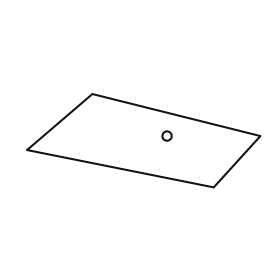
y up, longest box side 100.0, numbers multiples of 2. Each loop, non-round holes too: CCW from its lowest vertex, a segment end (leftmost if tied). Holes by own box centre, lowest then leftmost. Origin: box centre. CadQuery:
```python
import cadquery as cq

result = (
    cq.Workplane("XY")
    .moveTo(30.0, -20.0)
    .lineTo(50.0, 2.0)
    .lineTo(-22.0, 20.0)
    .lineTo(-50.0, -4.0)
    .close()
    .moveTo(10.0, 2.0)
    .circle(2.0)
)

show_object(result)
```